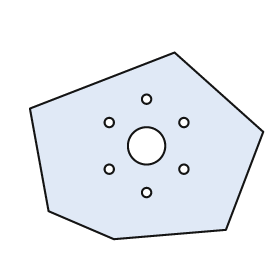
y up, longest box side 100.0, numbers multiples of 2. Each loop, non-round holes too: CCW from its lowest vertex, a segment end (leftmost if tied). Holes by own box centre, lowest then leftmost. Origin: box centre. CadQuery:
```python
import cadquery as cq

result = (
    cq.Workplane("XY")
    .moveTo(-14.0, -40.0)
    .lineTo(34.0, -36.0)
    .lineTo(50.0, 6.0)
    .lineTo(12.0, 40.0)
    .lineTo(-50.0, 16.0)
    .lineTo(-42.0, -28.0)
    .close()
    .moveTo(0.0, -20.0)
    .circle(2.0)
    .moveTo(-16.0, -10.0)
    .circle(2.0)
    .moveTo(16.0, -10.0)
    .circle(2.0)
    .moveTo(0.0, 0.0)
    .circle(8.0)
    .moveTo(-16.0, 10.0)
    .circle(2.0)
    .moveTo(16.0, 10.0)
    .circle(2.0)
    .moveTo(0.0, 20.0)
    .circle(2.0)
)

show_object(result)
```